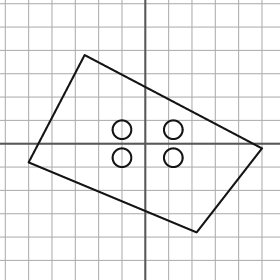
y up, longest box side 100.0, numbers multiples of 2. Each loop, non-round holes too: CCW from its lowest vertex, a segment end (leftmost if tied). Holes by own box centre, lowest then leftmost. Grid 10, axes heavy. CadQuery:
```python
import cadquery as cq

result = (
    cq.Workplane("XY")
    .moveTo(22.0, -38.0)
    .lineTo(50.0, -2.0)
    .lineTo(-26.0, 38.0)
    .lineTo(-50.0, -8.0)
    .close()
    .moveTo(-10.0, -6.0)
    .circle(4.0)
    .moveTo(12.0, -6.0)
    .circle(4.0)
    .moveTo(-10.0, 6.0)
    .circle(4.0)
    .moveTo(12.0, 6.0)
    .circle(4.0)
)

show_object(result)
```